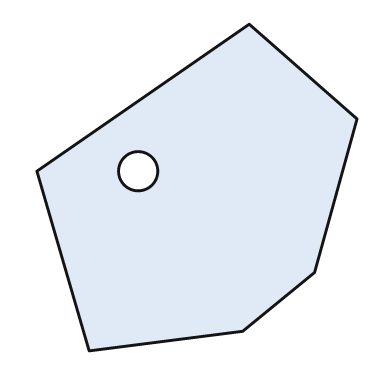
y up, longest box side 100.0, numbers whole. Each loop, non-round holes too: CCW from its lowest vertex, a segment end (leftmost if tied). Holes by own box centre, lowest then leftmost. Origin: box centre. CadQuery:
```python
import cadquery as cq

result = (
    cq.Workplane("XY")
    .moveTo(-33.0, -50.0)
    .lineTo(14.0, -44.0)
    .lineTo(36.0, -26.0)
    .lineTo(49.0, 21.0)
    .lineTo(16.0, 50.0)
    .lineTo(-49.0, 5.0)
    .close()
    .moveTo(-18.0, 5.0)
    .circle(6.0)
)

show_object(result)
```